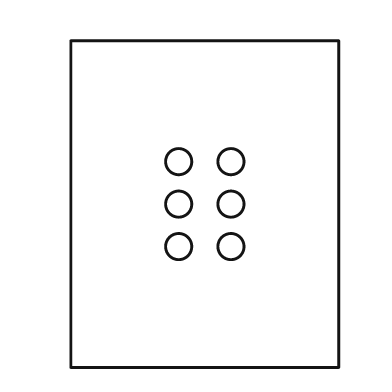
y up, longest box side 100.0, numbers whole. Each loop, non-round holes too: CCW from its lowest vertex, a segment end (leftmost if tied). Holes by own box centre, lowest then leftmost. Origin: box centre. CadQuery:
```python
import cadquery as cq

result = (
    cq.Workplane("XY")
    .moveTo(-41.0, -50.0)
    .lineTo(41.0, -50.0)
    .lineTo(41.0, 50.0)
    .lineTo(-41.0, 50.0)
    .close()
    .moveTo(-8.0, -13.0)
    .circle(4.0)
    .moveTo(8.0, -13.0)
    .circle(4.0)
    .moveTo(-8.0, 0.0)
    .circle(4.0)
    .moveTo(8.0, 0.0)
    .circle(4.0)
    .moveTo(-8.0, 13.0)
    .circle(4.0)
    .moveTo(8.0, 13.0)
    .circle(4.0)
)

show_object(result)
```